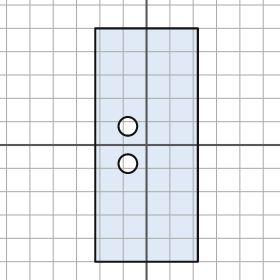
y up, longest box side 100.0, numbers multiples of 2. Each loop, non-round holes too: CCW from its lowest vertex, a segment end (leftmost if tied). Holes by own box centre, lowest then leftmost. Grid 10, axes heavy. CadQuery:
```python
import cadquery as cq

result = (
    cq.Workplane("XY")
    .moveTo(-22.0, -50.0)
    .lineTo(22.0, -50.0)
    .lineTo(22.0, 50.0)
    .lineTo(-22.0, 50.0)
    .close()
    .moveTo(-8.0, -8.0)
    .circle(4.0)
    .moveTo(-8.0, 8.0)
    .circle(4.0)
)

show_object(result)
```